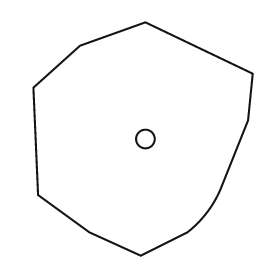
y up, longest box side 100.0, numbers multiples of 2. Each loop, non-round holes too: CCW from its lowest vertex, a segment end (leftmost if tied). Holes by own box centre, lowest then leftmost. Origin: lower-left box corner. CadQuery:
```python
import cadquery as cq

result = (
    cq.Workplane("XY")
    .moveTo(46.0, 0.0)
    .lineTo(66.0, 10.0)
    .threePointArc((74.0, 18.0), (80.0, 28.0))
    .lineTo(92.0, 58.0)
    .lineTo(94.0, 78.0)
    .lineTo(48.0, 100.0)
    .lineTo(20.0, 90.0)
    .lineTo(0.0, 72.0)
    .lineTo(2.0, 26.0)
    .lineTo(24.0, 10.0)
    .close()
    .moveTo(48.0, 50.0)
    .circle(4.0)
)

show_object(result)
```